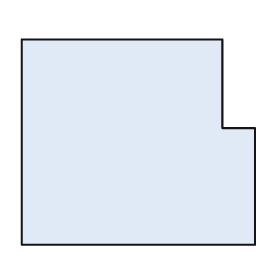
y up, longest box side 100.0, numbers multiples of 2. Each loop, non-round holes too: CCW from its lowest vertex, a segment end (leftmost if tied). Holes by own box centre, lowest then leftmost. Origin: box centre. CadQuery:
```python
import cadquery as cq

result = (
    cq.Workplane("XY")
    .moveTo(-50.0, -44.0)
    .lineTo(50.0, -44.0)
    .lineTo(50.0, 6.0)
    .lineTo(36.0, 6.0)
    .lineTo(36.0, 44.0)
    .lineTo(-50.0, 44.0)
    .close()
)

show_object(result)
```